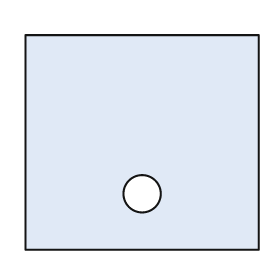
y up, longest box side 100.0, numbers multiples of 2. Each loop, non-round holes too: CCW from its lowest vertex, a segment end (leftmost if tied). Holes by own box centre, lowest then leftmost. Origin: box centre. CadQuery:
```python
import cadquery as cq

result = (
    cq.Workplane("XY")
    .moveTo(-50.0, -46.0)
    .lineTo(50.0, -46.0)
    .lineTo(50.0, 46.0)
    .lineTo(-50.0, 46.0)
    .close()
    .moveTo(0.0, -22.0)
    .circle(8.0)
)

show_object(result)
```